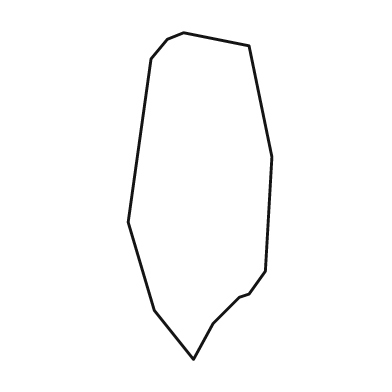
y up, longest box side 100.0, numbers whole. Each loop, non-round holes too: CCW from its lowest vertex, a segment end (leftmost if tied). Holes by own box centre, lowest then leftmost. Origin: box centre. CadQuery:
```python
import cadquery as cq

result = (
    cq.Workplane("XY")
    .moveTo(-2.0, -50.0)
    .lineTo(4.0, -39.0)
    .lineTo(12.0, -31.0)
    .lineTo(15.0, -30.0)
    .lineTo(20.0, -23.0)
    .lineTo(22.0, 12.0)
    .lineTo(15.0, 46.0)
    .lineTo(-5.0, 50.0)
    .lineTo(-10.0, 48.0)
    .lineTo(-15.0, 42.0)
    .lineTo(-22.0, -8.0)
    .lineTo(-14.0, -35.0)
    .close()
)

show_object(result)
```